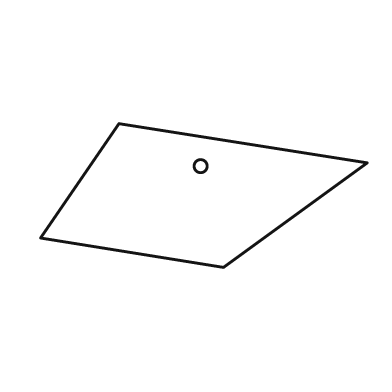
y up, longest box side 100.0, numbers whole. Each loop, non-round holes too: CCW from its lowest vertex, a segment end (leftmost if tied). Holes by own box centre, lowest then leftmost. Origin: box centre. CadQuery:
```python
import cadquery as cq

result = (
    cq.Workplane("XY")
    .moveTo(6.0, -22.0)
    .lineTo(50.0, 10.0)
    .lineTo(-26.0, 22.0)
    .lineTo(-50.0, -13.0)
    .close()
    .moveTo(-1.0, 9.0)
    .circle(2.0)
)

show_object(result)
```